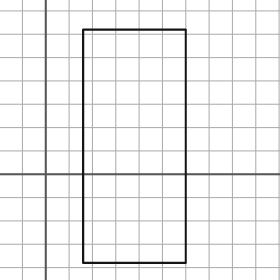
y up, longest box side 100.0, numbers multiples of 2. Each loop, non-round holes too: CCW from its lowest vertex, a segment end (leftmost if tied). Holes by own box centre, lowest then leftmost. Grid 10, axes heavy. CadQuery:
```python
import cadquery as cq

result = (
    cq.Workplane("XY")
    .moveTo(16.0, -38.0)
    .lineTo(60.0, -38.0)
    .lineTo(60.0, 62.0)
    .lineTo(16.0, 62.0)
    .close()
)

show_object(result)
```